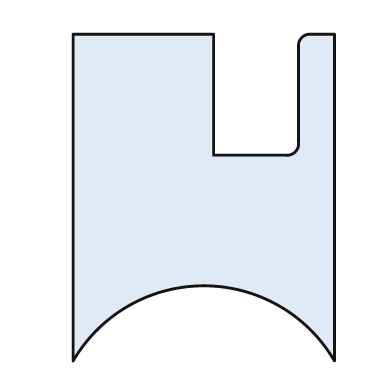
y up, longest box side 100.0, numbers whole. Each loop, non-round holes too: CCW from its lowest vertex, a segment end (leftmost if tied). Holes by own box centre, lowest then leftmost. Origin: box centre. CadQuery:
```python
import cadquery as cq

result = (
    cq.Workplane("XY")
    .moveTo(-40.0, -50.0)
    .threePointArc((0.0, -27.0), (40.0, -50.0))
    .lineTo(40.0, 50.0)
    .lineTo(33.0, 50.0)
    .threePointArc((30.0, 49.0), (29.0, 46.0))
    .lineTo(29.0, 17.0)
    .threePointArc((28.0, 14.0), (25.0, 13.0))
    .lineTo(3.0, 13.0)
    .lineTo(3.0, 50.0)
    .lineTo(-40.0, 50.0)
    .close()
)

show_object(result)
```